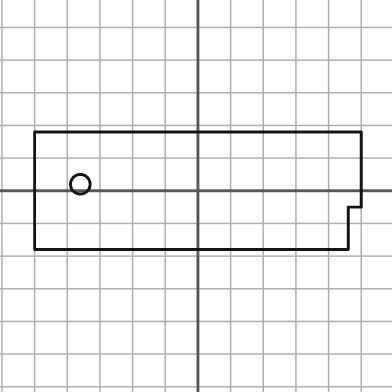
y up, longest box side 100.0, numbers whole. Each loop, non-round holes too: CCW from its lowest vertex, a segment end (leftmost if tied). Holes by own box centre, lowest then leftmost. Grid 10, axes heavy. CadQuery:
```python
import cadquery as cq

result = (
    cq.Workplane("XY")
    .moveTo(-50.0, -18.0)
    .lineTo(46.0, -18.0)
    .lineTo(46.0, -5.0)
    .lineTo(50.0, -5.0)
    .lineTo(50.0, 18.0)
    .lineTo(-50.0, 18.0)
    .close()
    .moveTo(-36.0, 2.0)
    .circle(3.0)
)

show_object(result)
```